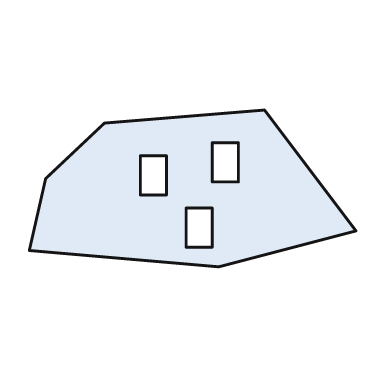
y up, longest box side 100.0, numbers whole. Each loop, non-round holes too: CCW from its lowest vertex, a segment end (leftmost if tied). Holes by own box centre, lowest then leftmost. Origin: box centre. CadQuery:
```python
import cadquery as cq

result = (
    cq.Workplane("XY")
    .moveTo(8.0, -24.0)
    .lineTo(50.0, -13.0)
    .lineTo(22.0, 24.0)
    .lineTo(-27.0, 20.0)
    .lineTo(-45.0, 3.0)
    .lineTo(-50.0, -19.0)
    .close()
    .moveTo(-2.0, -18.0)
    .lineTo(6.0, -18.0)
    .lineTo(6.0, -6.0)
    .lineTo(-2.0, -6.0)
    .close()
    .moveTo(-16.0, -2.0)
    .lineTo(-8.0, -2.0)
    .lineTo(-8.0, 10.0)
    .lineTo(-16.0, 10.0)
    .close()
    .moveTo(6.0, 2.0)
    .lineTo(14.0, 2.0)
    .lineTo(14.0, 14.0)
    .lineTo(6.0, 14.0)
    .close()
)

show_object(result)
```